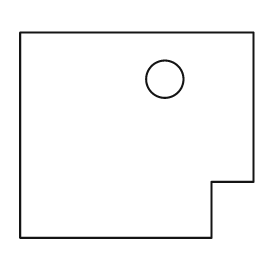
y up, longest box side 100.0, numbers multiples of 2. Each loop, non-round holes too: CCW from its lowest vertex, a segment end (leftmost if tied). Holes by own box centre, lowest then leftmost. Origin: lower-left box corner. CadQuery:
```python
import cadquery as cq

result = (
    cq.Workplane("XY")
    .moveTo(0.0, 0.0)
    .lineTo(82.0, 0.0)
    .lineTo(82.0, 24.0)
    .lineTo(100.0, 24.0)
    .lineTo(100.0, 88.0)
    .lineTo(0.0, 88.0)
    .close()
    .moveTo(62.0, 68.0)
    .circle(8.0)
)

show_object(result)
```